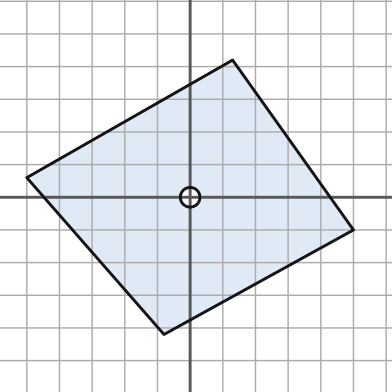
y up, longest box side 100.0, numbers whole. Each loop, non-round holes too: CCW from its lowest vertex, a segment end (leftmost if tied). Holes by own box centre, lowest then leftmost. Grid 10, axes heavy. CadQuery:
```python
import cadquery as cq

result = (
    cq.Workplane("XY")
    .moveTo(-8.0, -42.0)
    .lineTo(50.0, -10.0)
    .lineTo(13.0, 42.0)
    .lineTo(-50.0, 6.0)
    .close()
    .moveTo(0.0, 0.0)
    .circle(3.0)
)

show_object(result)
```